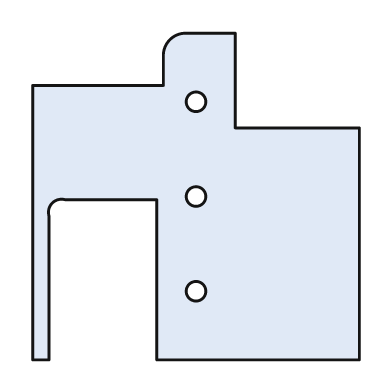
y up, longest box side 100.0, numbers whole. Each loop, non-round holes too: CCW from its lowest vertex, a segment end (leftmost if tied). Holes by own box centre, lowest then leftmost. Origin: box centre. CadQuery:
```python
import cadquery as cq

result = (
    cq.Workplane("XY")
    .moveTo(-50.0, -50.0)
    .lineTo(-45.0, -50.0)
    .lineTo(-45.0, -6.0)
    .threePointArc((-44.0, -2.0), (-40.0, -1.0))
    .lineTo(-12.0, -1.0)
    .lineTo(-12.0, -50.0)
    .lineTo(50.0, -50.0)
    .lineTo(50.0, 21.0)
    .lineTo(12.0, 21.0)
    .lineTo(12.0, 50.0)
    .lineTo(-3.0, 50.0)
    .threePointArc((-8.0, 48.0), (-10.0, 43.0))
    .lineTo(-10.0, 34.0)
    .lineTo(-50.0, 34.0)
    .close()
    .moveTo(0.0, -29.0)
    .circle(3.0)
    .moveTo(0.0, 0.0)
    .circle(3.0)
    .moveTo(0.0, 29.0)
    .circle(3.0)
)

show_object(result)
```